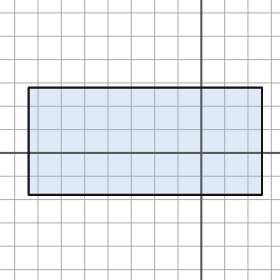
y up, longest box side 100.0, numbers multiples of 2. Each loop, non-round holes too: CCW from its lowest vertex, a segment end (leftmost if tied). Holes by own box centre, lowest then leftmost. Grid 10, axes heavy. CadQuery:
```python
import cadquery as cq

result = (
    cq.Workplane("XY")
    .moveTo(-74.0, -18.0)
    .lineTo(26.0, -18.0)
    .lineTo(26.0, 28.0)
    .lineTo(-74.0, 28.0)
    .close()
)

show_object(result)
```